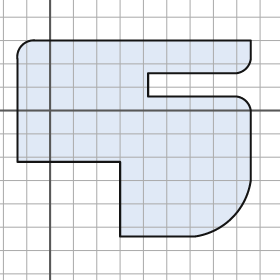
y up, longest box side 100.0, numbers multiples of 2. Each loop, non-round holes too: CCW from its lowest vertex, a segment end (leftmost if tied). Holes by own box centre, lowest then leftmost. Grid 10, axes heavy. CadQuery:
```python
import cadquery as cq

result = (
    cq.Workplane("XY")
    .moveTo(30.0, -54.0)
    .lineTo(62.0, -54.0)
    .threePointArc((78.0, -46.0), (86.0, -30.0))
    .lineTo(86.0, 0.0)
    .threePointArc((84.0, 4.0), (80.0, 6.0))
    .lineTo(42.0, 6.0)
    .lineTo(42.0, 16.0)
    .lineTo(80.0, 16.0)
    .threePointArc((84.0, 18.0), (86.0, 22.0))
    .lineTo(86.0, 30.0)
    .lineTo(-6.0, 30.0)
    .threePointArc((-12.0, 28.0), (-14.0, 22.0))
    .lineTo(-14.0, -22.0)
    .lineTo(30.0, -22.0)
    .close()
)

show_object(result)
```